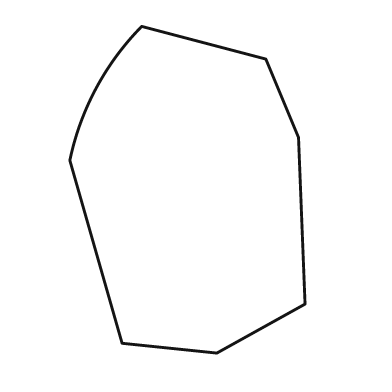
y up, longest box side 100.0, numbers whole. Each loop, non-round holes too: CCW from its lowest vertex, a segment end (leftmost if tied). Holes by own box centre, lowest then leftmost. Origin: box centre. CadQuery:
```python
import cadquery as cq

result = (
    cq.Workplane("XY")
    .moveTo(9.0, -50.0)
    .lineTo(36.0, -35.0)
    .lineTo(34.0, 16.0)
    .lineTo(24.0, 40.0)
    .lineTo(-14.0, 50.0)
    .threePointArc((-28.0, 31.0), (-36.0, 9.0))
    .lineTo(-20.0, -47.0)
    .close()
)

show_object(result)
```